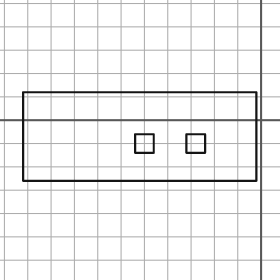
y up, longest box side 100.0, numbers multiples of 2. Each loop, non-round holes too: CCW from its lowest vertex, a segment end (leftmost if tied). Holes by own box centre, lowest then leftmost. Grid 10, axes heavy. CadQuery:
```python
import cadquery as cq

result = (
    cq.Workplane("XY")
    .moveTo(-102.0, -26.0)
    .lineTo(-2.0, -26.0)
    .lineTo(-2.0, 12.0)
    .lineTo(-102.0, 12.0)
    .close()
    .moveTo(-54.0, -14.0)
    .lineTo(-46.0, -14.0)
    .lineTo(-46.0, -6.0)
    .lineTo(-54.0, -6.0)
    .close()
    .moveTo(-32.0, -14.0)
    .lineTo(-24.0, -14.0)
    .lineTo(-24.0, -6.0)
    .lineTo(-32.0, -6.0)
    .close()
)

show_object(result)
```